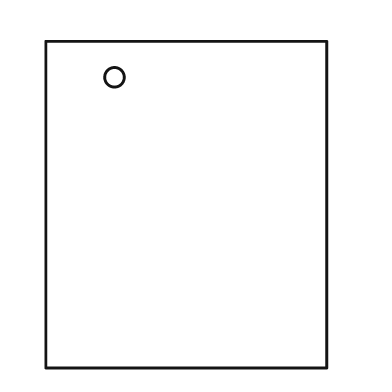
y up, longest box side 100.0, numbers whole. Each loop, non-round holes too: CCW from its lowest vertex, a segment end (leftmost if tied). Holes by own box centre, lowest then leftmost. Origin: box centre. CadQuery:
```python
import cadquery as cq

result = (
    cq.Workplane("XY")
    .moveTo(-43.0, -50.0)
    .lineTo(43.0, -50.0)
    .lineTo(43.0, 50.0)
    .lineTo(-43.0, 50.0)
    .close()
    .moveTo(-22.0, 39.0)
    .circle(3.0)
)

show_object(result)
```